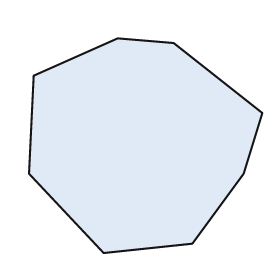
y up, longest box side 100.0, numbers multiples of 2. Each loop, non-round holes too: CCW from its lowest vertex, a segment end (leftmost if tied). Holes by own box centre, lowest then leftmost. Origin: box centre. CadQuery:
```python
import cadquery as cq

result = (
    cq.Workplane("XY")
    .moveTo(-18.0, -46.0)
    .lineTo(20.0, -42.0)
    .lineTo(42.0, -12.0)
    .lineTo(50.0, 14.0)
    .lineTo(12.0, 44.0)
    .lineTo(-12.0, 46.0)
    .lineTo(-48.0, 30.0)
    .lineTo(-50.0, -12.0)
    .close()
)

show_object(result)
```